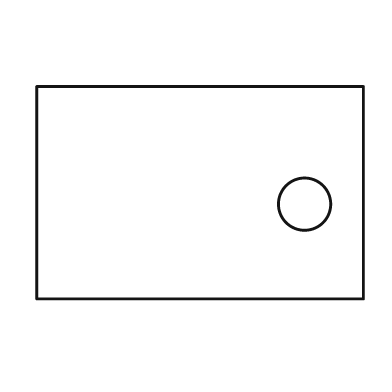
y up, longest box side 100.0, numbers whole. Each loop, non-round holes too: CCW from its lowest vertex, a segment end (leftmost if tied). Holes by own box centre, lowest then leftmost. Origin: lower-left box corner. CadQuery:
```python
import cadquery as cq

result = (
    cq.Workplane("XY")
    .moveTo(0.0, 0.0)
    .lineTo(100.0, 0.0)
    .lineTo(100.0, 65.0)
    .lineTo(0.0, 65.0)
    .close()
    .moveTo(82.0, 29.0)
    .circle(8.0)
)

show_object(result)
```